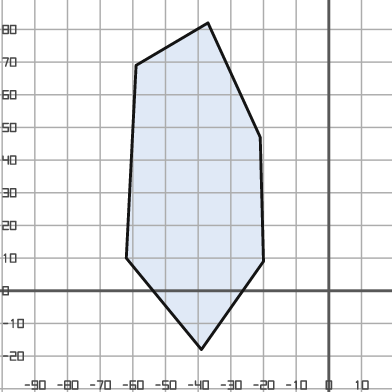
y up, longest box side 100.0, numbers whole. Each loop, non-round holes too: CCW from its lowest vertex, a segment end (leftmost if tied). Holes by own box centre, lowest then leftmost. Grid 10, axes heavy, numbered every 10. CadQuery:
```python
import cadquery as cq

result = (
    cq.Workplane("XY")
    .moveTo(-39.0, -18.0)
    .lineTo(-20.0, 9.0)
    .lineTo(-21.0, 47.0)
    .lineTo(-37.0, 82.0)
    .lineTo(-59.0, 69.0)
    .lineTo(-62.0, 10.0)
    .close()
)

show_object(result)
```